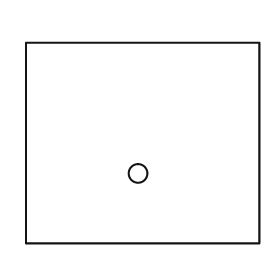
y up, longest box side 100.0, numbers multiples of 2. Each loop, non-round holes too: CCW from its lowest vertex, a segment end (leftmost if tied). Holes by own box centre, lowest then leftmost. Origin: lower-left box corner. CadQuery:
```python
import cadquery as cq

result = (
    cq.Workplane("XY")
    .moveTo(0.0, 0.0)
    .lineTo(100.0, 0.0)
    .lineTo(100.0, 86.0)
    .lineTo(0.0, 86.0)
    .close()
    .moveTo(48.0, 30.0)
    .circle(4.0)
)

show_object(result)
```